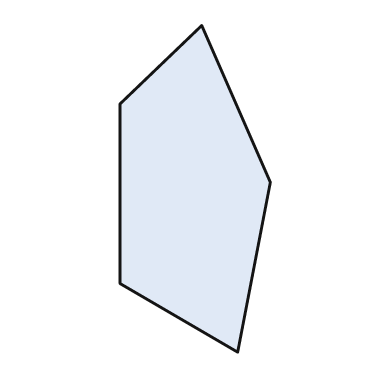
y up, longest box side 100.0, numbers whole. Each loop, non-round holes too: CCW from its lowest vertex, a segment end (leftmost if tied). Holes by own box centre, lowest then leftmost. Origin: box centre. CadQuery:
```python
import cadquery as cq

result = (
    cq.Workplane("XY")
    .moveTo(13.0, -50.0)
    .lineTo(23.0, 2.0)
    .lineTo(2.0, 50.0)
    .lineTo(-23.0, 26.0)
    .lineTo(-23.0, -29.0)
    .close()
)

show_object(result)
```